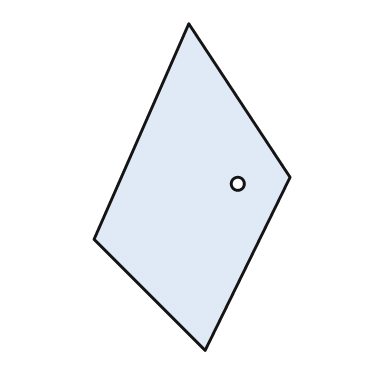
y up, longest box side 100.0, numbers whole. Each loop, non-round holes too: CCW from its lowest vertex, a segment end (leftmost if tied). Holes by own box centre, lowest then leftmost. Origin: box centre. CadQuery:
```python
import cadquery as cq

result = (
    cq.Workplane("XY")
    .moveTo(4.0, -50.0)
    .lineTo(30.0, 3.0)
    .lineTo(-1.0, 50.0)
    .lineTo(-30.0, -16.0)
    .close()
    .moveTo(14.0, 1.0)
    .circle(2.0)
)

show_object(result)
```